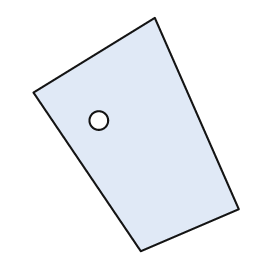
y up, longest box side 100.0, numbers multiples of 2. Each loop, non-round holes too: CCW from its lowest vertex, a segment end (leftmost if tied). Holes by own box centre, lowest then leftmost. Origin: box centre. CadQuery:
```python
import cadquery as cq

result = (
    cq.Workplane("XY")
    .moveTo(2.0, -50.0)
    .lineTo(44.0, -32.0)
    .lineTo(8.0, 50.0)
    .lineTo(-44.0, 18.0)
    .close()
    .moveTo(-16.0, 6.0)
    .circle(4.0)
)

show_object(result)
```